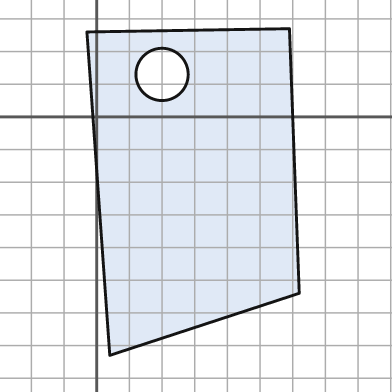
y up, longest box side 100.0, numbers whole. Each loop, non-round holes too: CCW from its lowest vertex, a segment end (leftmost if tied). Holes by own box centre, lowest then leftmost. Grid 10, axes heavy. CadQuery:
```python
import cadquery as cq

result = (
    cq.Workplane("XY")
    .moveTo(4.0, -73.0)
    .lineTo(62.0, -54.0)
    .lineTo(59.0, 27.0)
    .lineTo(-3.0, 26.0)
    .close()
    .moveTo(20.0, 13.0)
    .circle(8.0)
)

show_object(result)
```